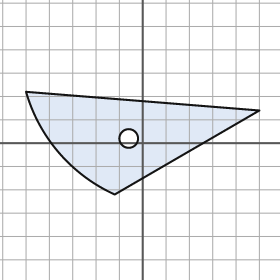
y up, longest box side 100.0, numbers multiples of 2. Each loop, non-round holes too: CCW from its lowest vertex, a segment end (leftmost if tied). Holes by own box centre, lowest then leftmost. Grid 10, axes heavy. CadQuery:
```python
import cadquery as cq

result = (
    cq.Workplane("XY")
    .moveTo(-12.0, -22.0)
    .lineTo(50.0, 14.0)
    .lineTo(-50.0, 22.0)
    .threePointArc((-36.0, -4.0), (-12.0, -22.0))
    .close()
    .moveTo(-6.0, 2.0)
    .circle(4.0)
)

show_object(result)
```